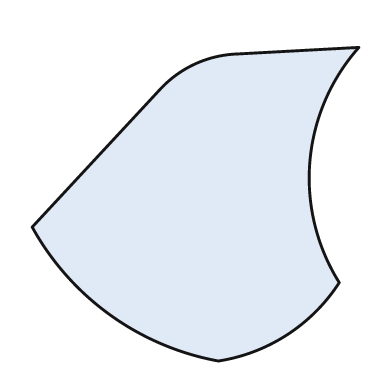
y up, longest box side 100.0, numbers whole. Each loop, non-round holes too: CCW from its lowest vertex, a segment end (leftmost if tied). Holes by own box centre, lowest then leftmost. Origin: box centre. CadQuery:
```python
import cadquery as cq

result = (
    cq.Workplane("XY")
    .moveTo(7.0, -48.0)
    .threePointArc((28.0, -40.0), (44.0, -24.0))
    .threePointArc((35.0, 13.0), (50.0, 48.0))
    .lineTo(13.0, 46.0)
    .threePointArc((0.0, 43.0), (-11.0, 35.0))
    .lineTo(-50.0, -7.0)
    .threePointArc((-26.0, -34.0), (7.0, -48.0))
    .close()
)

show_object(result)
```